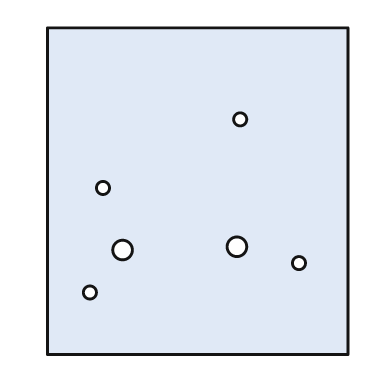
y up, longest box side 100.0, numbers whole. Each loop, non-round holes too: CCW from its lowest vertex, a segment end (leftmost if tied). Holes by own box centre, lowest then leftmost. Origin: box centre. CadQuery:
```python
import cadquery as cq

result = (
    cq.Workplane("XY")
    .moveTo(-46.0, -50.0)
    .lineTo(46.0, -50.0)
    .lineTo(46.0, 50.0)
    .lineTo(-46.0, 50.0)
    .close()
    .moveTo(-33.0, -31.0)
    .circle(2.0)
    .moveTo(31.0, -22.0)
    .circle(2.0)
    .moveTo(-23.0, -18.0)
    .circle(3.0)
    .moveTo(12.0, -17.0)
    .circle(3.0)
    .moveTo(-29.0, 1.0)
    .circle(2.0)
    .moveTo(13.0, 22.0)
    .circle(2.0)
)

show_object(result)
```